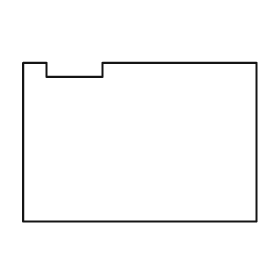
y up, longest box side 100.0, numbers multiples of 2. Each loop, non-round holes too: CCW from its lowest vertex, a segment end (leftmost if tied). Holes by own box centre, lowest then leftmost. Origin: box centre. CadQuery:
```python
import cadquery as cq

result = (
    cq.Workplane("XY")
    .moveTo(-50.0, -34.0)
    .lineTo(50.0, -34.0)
    .lineTo(50.0, 34.0)
    .lineTo(-16.0, 34.0)
    .lineTo(-16.0, 28.0)
    .lineTo(-40.0, 28.0)
    .lineTo(-40.0, 34.0)
    .lineTo(-50.0, 34.0)
    .close()
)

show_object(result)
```